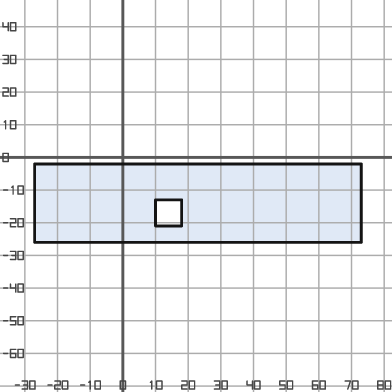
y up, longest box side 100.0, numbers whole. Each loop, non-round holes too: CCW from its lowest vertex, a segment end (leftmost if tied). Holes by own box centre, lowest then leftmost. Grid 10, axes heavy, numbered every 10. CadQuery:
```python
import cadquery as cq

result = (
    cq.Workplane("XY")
    .moveTo(-27.0, -26.0)
    .lineTo(73.0, -26.0)
    .lineTo(73.0, -2.0)
    .lineTo(-27.0, -2.0)
    .close()
    .moveTo(10.0, -21.0)
    .lineTo(18.0, -21.0)
    .lineTo(18.0, -13.0)
    .lineTo(10.0, -13.0)
    .close()
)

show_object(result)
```